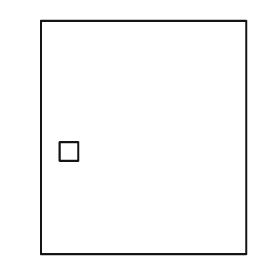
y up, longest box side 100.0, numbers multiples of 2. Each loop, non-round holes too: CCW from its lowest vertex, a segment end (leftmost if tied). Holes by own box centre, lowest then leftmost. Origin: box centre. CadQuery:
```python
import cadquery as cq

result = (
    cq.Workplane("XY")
    .moveTo(-44.0, -50.0)
    .lineTo(44.0, -50.0)
    .lineTo(44.0, 50.0)
    .lineTo(-44.0, 50.0)
    .close()
    .moveTo(-36.0, -10.0)
    .lineTo(-28.0, -10.0)
    .lineTo(-28.0, -2.0)
    .lineTo(-36.0, -2.0)
    .close()
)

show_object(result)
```